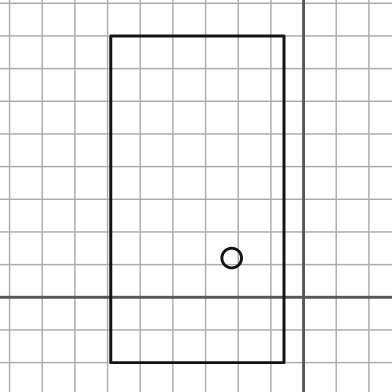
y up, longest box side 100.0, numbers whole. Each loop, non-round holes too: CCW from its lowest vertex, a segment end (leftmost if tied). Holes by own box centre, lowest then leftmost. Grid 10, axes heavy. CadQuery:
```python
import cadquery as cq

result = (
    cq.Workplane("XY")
    .moveTo(-59.0, -20.0)
    .lineTo(-6.0, -20.0)
    .lineTo(-6.0, 80.0)
    .lineTo(-59.0, 80.0)
    .close()
    .moveTo(-22.0, 12.0)
    .circle(3.0)
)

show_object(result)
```